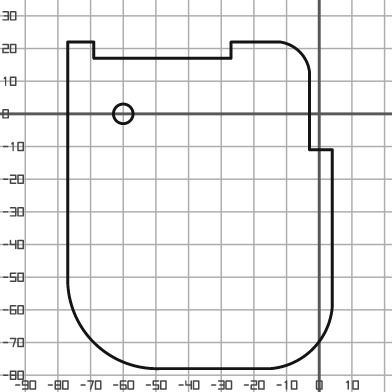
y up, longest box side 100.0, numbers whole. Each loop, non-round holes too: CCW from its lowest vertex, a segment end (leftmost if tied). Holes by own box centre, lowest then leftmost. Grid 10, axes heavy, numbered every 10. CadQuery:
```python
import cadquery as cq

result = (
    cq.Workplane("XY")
    .moveTo(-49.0, -78.0)
    .lineTo(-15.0, -78.0)
    .threePointArc((-2.0, -72.0), (4.0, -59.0))
    .lineTo(4.0, -11.0)
    .lineTo(-3.0, -11.0)
    .lineTo(-3.0, 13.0)
    .threePointArc((-6.0, 19.0), (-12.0, 22.0))
    .lineTo(-27.0, 22.0)
    .lineTo(-27.0, 17.0)
    .lineTo(-69.0, 17.0)
    .lineTo(-69.0, 22.0)
    .lineTo(-77.0, 22.0)
    .lineTo(-77.0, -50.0)
    .threePointArc((-69.0, -70.0), (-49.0, -78.0))
    .close()
    .moveTo(-60.0, 0.0)
    .circle(3.0)
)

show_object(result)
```